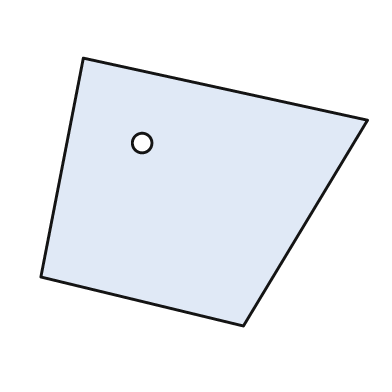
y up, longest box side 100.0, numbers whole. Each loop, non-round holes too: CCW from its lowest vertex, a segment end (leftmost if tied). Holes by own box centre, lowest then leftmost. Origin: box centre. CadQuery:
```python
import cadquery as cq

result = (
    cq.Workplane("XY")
    .moveTo(12.0, -41.0)
    .lineTo(50.0, 22.0)
    .lineTo(-37.0, 41.0)
    .lineTo(-50.0, -26.0)
    .close()
    .moveTo(-19.0, 15.0)
    .circle(3.0)
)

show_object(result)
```